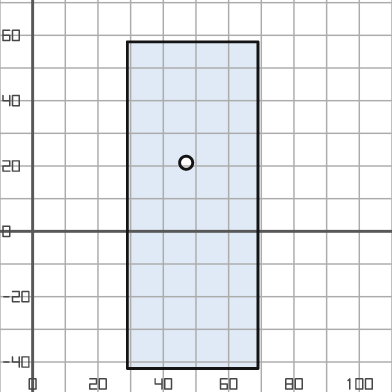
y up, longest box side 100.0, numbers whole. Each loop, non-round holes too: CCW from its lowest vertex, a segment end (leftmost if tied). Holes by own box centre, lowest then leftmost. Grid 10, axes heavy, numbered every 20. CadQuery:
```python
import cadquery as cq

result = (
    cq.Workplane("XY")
    .moveTo(29.0, -42.0)
    .lineTo(69.0, -42.0)
    .lineTo(69.0, 58.0)
    .lineTo(29.0, 58.0)
    .close()
    .moveTo(47.0, 21.0)
    .circle(2.0)
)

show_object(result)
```